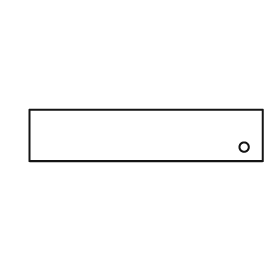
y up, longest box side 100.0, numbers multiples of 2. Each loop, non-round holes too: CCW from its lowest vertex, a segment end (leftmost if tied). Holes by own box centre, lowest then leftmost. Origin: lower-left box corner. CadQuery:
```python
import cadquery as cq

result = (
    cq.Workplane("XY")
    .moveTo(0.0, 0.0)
    .lineTo(100.0, 0.0)
    .lineTo(100.0, 22.0)
    .lineTo(0.0, 22.0)
    .close()
    .moveTo(92.0, 6.0)
    .circle(2.0)
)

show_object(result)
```